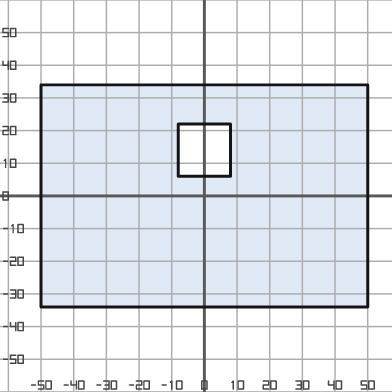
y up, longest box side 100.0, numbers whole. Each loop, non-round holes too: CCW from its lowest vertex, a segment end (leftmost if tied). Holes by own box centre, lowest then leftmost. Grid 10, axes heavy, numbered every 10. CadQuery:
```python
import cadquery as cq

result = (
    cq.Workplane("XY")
    .moveTo(-50.0, -34.0)
    .lineTo(50.0, -34.0)
    .lineTo(50.0, 34.0)
    .lineTo(-50.0, 34.0)
    .close()
    .moveTo(-8.0, 6.0)
    .lineTo(8.0, 6.0)
    .lineTo(8.0, 22.0)
    .lineTo(-8.0, 22.0)
    .close()
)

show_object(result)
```